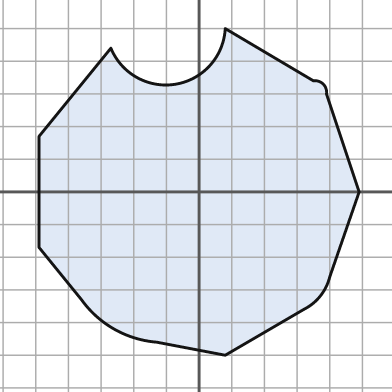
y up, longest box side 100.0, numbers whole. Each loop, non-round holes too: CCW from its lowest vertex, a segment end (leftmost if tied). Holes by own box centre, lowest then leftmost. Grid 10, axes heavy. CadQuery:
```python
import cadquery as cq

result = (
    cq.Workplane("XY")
    .moveTo(8.0, -50.0)
    .lineTo(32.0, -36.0)
    .threePointArc((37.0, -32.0), (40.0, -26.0))
    .lineTo(49.0, 0.0)
    .lineTo(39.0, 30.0)
    .threePointArc((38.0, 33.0), (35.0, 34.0))
    .lineTo(8.0, 50.0)
    .threePointArc((-7.0, 33.0), (-27.0, 44.0))
    .lineTo(-49.0, 17.0)
    .lineTo(-49.0, -17.0)
    .lineTo(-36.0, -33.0)
    .threePointArc((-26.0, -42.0), (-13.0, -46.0))
    .close()
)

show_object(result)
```